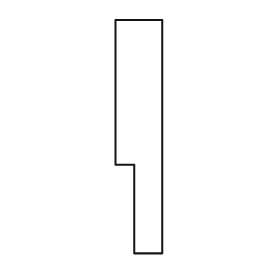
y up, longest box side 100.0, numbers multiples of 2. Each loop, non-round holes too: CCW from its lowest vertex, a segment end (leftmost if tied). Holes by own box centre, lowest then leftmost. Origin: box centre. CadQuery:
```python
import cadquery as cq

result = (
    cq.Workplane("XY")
    .moveTo(-2.0, -50.0)
    .lineTo(10.0, -50.0)
    .lineTo(10.0, 50.0)
    .lineTo(-10.0, 50.0)
    .lineTo(-10.0, -12.0)
    .lineTo(-2.0, -12.0)
    .close()
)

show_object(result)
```